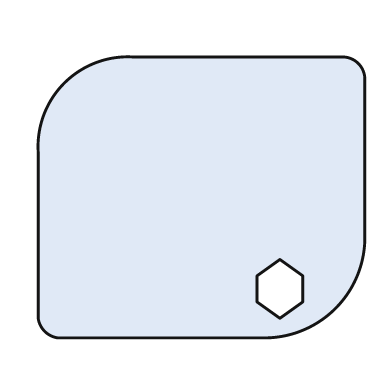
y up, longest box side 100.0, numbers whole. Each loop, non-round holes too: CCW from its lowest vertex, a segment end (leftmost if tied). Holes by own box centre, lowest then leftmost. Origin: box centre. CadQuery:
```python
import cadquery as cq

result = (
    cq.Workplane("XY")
    .moveTo(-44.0, -43.0)
    .lineTo(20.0, -43.0)
    .threePointArc((41.0, -34.0), (50.0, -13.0))
    .lineTo(50.0, 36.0)
    .threePointArc((48.0, 41.0), (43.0, 43.0))
    .lineTo(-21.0, 43.0)
    .threePointArc((-42.0, 35.0), (-50.0, 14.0))
    .lineTo(-50.0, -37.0)
    .threePointArc((-48.0, -41.0), (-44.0, -43.0))
    .close()
    .moveTo(24.0, -37.0)
    .lineTo(31.0, -32.0)
    .lineTo(31.0, -24.0)
    .lineTo(24.0, -19.0)
    .lineTo(17.0, -24.0)
    .lineTo(17.0, -32.0)
    .close()
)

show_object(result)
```